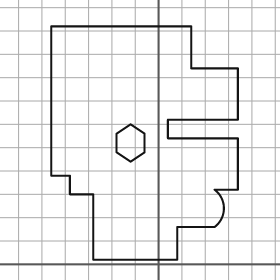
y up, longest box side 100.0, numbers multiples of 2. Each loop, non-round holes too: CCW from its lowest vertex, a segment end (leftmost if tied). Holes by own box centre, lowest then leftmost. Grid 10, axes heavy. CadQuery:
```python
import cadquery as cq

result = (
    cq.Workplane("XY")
    .moveTo(-28.0, 2.0)
    .lineTo(8.0, 2.0)
    .lineTo(8.0, 16.0)
    .lineTo(24.0, 16.0)
    .threePointArc((28.0, 24.0), (24.0, 32.0))
    .lineTo(34.0, 32.0)
    .lineTo(34.0, 54.0)
    .lineTo(4.0, 54.0)
    .lineTo(4.0, 62.0)
    .lineTo(34.0, 62.0)
    .lineTo(34.0, 84.0)
    .lineTo(14.0, 84.0)
    .lineTo(14.0, 102.0)
    .lineTo(-46.0, 102.0)
    .lineTo(-46.0, 38.0)
    .lineTo(-38.0, 38.0)
    .lineTo(-38.0, 30.0)
    .lineTo(-28.0, 30.0)
    .close()
    .moveTo(-12.0, 44.0)
    .lineTo(-6.0, 48.0)
    .lineTo(-6.0, 56.0)
    .lineTo(-12.0, 60.0)
    .lineTo(-18.0, 56.0)
    .lineTo(-18.0, 48.0)
    .close()
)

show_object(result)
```